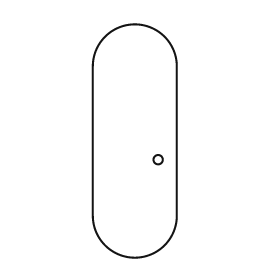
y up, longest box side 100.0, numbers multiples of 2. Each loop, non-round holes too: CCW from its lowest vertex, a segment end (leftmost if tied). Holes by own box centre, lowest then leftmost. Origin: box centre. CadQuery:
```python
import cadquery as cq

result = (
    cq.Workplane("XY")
    .moveTo(-18.0, -32.0)
    .threePointArc((0.0, -50.0), (18.0, -32.0))
    .lineTo(18.0, 32.0)
    .threePointArc((0.0, 50.0), (-18.0, 32.0))
    .close()
    .moveTo(10.0, -8.0)
    .circle(2.0)
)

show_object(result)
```